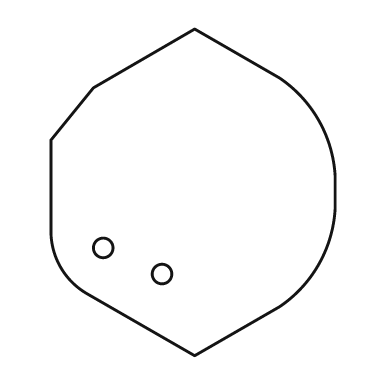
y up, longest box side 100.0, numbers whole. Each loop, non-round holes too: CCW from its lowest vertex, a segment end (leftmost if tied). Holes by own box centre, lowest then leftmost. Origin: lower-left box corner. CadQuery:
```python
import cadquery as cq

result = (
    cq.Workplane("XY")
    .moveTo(44.0, 0.0)
    .lineTo(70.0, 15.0)
    .threePointArc((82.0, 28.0), (87.0, 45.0))
    .lineTo(87.0, 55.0)
    .threePointArc((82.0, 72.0), (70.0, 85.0))
    .lineTo(44.0, 100.0)
    .lineTo(13.0, 82.0)
    .lineTo(0.0, 66.0)
    .lineTo(0.0, 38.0)
    .threePointArc((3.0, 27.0), (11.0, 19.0))
    .close()
    .moveTo(34.0, 25.0)
    .circle(3.0)
    .moveTo(16.0, 33.0)
    .circle(3.0)
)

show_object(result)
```